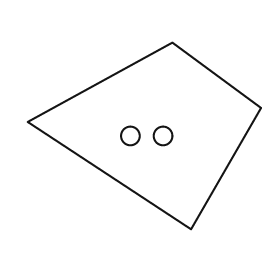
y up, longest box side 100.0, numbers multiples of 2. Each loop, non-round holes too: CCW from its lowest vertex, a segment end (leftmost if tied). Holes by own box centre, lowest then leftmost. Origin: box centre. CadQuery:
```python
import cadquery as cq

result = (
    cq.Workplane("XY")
    .moveTo(20.0, -40.0)
    .lineTo(50.0, 12.0)
    .lineTo(12.0, 40.0)
    .lineTo(-50.0, 6.0)
    .close()
    .moveTo(-6.0, 0.0)
    .circle(4.0)
    .moveTo(8.0, 0.0)
    .circle(4.0)
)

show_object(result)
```